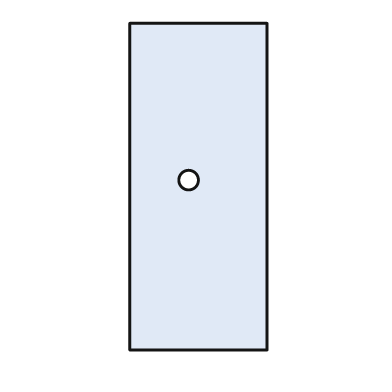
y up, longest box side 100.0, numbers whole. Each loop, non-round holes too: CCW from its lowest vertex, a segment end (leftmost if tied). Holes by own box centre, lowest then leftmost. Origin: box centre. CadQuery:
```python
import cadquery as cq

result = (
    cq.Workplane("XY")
    .moveTo(-21.0, -50.0)
    .lineTo(21.0, -50.0)
    .lineTo(21.0, 50.0)
    .lineTo(-21.0, 50.0)
    .close()
    .moveTo(-3.0, 2.0)
    .circle(3.0)
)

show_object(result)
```